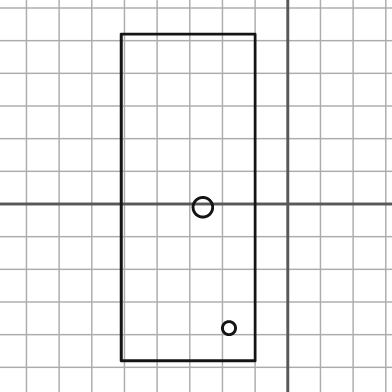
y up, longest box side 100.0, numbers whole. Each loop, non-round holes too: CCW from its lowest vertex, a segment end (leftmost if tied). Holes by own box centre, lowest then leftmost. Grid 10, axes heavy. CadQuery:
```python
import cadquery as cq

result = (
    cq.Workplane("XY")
    .moveTo(-51.0, -48.0)
    .lineTo(-10.0, -48.0)
    .lineTo(-10.0, 52.0)
    .lineTo(-51.0, 52.0)
    .close()
    .moveTo(-18.0, -38.0)
    .circle(2.0)
    .moveTo(-26.0, -1.0)
    .circle(3.0)
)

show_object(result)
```